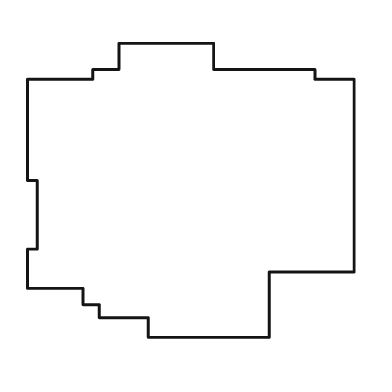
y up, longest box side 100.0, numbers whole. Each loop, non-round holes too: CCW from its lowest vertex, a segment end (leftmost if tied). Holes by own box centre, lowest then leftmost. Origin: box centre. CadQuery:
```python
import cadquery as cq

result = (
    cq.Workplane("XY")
    .moveTo(-13.0, -45.0)
    .lineTo(24.0, -45.0)
    .lineTo(24.0, -25.0)
    .lineTo(50.0, -25.0)
    .lineTo(50.0, 34.0)
    .lineTo(38.0, 34.0)
    .lineTo(38.0, 37.0)
    .lineTo(7.0, 37.0)
    .lineTo(7.0, 45.0)
    .lineTo(-22.0, 45.0)
    .lineTo(-22.0, 37.0)
    .lineTo(-30.0, 37.0)
    .lineTo(-30.0, 34.0)
    .lineTo(-50.0, 34.0)
    .lineTo(-50.0, 3.0)
    .lineTo(-47.0, 3.0)
    .lineTo(-47.0, -18.0)
    .lineTo(-50.0, -18.0)
    .lineTo(-50.0, -30.0)
    .lineTo(-33.0, -30.0)
    .lineTo(-33.0, -35.0)
    .lineTo(-28.0, -35.0)
    .lineTo(-28.0, -39.0)
    .lineTo(-13.0, -39.0)
    .close()
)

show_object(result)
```